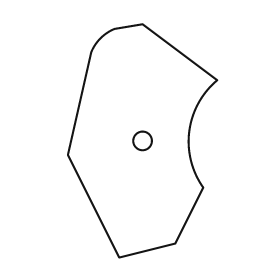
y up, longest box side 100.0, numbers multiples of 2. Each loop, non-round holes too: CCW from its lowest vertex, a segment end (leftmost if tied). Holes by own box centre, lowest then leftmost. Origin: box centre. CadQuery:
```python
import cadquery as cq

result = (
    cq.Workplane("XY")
    .moveTo(-10.0, -50.0)
    .lineTo(14.0, -44.0)
    .lineTo(26.0, -20.0)
    .threePointArc((20.0, 4.0), (32.0, 26.0))
    .lineTo(0.0, 50.0)
    .lineTo(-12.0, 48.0)
    .threePointArc((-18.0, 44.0), (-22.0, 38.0))
    .lineTo(-32.0, -6.0)
    .close()
    .moveTo(0.0, 0.0)
    .circle(4.0)
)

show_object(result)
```